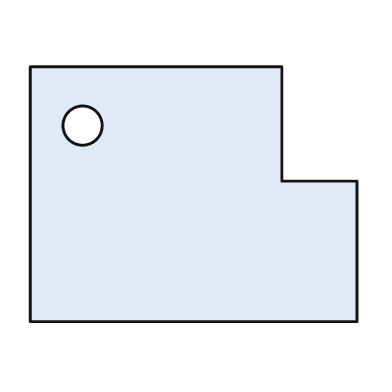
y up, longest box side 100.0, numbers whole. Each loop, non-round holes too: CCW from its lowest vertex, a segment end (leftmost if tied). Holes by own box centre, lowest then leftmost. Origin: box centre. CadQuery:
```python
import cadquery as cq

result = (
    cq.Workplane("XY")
    .moveTo(-50.0, -39.0)
    .lineTo(50.0, -39.0)
    .lineTo(50.0, 4.0)
    .lineTo(27.0, 4.0)
    .lineTo(27.0, 39.0)
    .lineTo(-50.0, 39.0)
    .close()
    .moveTo(-34.0, 21.0)
    .circle(6.0)
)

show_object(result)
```